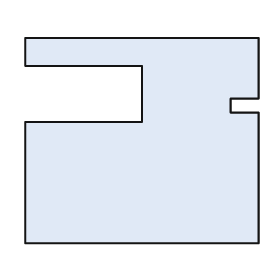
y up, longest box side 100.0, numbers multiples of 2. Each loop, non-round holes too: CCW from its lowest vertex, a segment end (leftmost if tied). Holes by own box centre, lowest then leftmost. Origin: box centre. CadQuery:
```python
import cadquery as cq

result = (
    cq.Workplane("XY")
    .moveTo(-50.0, -44.0)
    .lineTo(50.0, -44.0)
    .lineTo(50.0, 12.0)
    .lineTo(38.0, 12.0)
    .lineTo(38.0, 18.0)
    .lineTo(50.0, 18.0)
    .lineTo(50.0, 44.0)
    .lineTo(-50.0, 44.0)
    .lineTo(-50.0, 32.0)
    .lineTo(0.0, 32.0)
    .lineTo(0.0, 8.0)
    .lineTo(-50.0, 8.0)
    .close()
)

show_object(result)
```